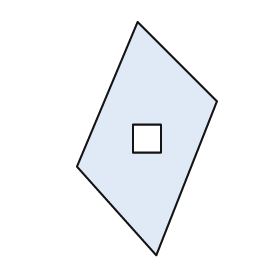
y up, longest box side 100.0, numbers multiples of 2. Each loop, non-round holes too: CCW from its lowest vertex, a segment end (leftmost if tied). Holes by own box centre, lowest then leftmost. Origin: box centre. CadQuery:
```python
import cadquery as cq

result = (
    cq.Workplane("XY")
    .moveTo(4.0, -50.0)
    .lineTo(30.0, 16.0)
    .lineTo(-4.0, 50.0)
    .lineTo(-30.0, -12.0)
    .close()
    .moveTo(-6.0, -6.0)
    .lineTo(6.0, -6.0)
    .lineTo(6.0, 6.0)
    .lineTo(-6.0, 6.0)
    .close()
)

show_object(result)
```